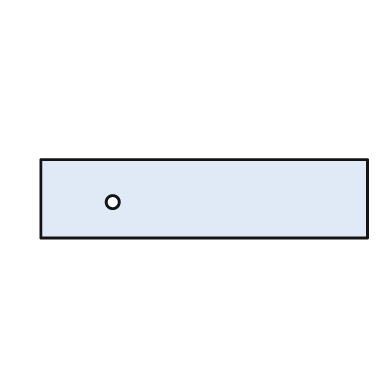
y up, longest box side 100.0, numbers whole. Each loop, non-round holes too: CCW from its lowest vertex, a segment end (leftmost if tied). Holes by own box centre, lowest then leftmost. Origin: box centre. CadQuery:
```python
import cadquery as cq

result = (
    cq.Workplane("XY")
    .moveTo(-50.0, -12.0)
    .lineTo(50.0, -12.0)
    .lineTo(50.0, 12.0)
    .lineTo(-50.0, 12.0)
    .close()
    .moveTo(-28.0, -1.0)
    .circle(2.0)
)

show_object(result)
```